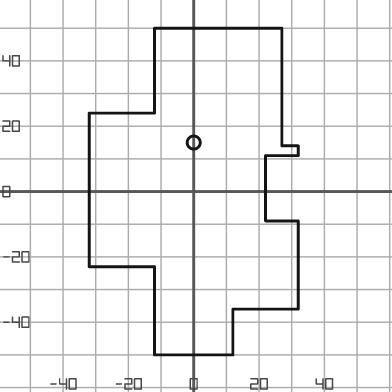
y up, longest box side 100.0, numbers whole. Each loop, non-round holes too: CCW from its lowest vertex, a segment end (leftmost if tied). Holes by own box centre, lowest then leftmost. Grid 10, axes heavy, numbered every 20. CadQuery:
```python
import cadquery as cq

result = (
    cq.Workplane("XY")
    .moveTo(-12.0, -50.0)
    .lineTo(12.0, -50.0)
    .lineTo(12.0, -36.0)
    .lineTo(32.0, -36.0)
    .lineTo(32.0, -9.0)
    .lineTo(22.0, -9.0)
    .lineTo(22.0, 11.0)
    .lineTo(32.0, 11.0)
    .lineTo(32.0, 14.0)
    .lineTo(27.0, 14.0)
    .lineTo(27.0, 50.0)
    .lineTo(-12.0, 50.0)
    .lineTo(-12.0, 24.0)
    .lineTo(-32.0, 24.0)
    .lineTo(-32.0, -23.0)
    .lineTo(-12.0, -23.0)
    .close()
    .moveTo(0.0, 15.0)
    .circle(2.0)
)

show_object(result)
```